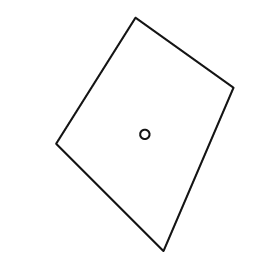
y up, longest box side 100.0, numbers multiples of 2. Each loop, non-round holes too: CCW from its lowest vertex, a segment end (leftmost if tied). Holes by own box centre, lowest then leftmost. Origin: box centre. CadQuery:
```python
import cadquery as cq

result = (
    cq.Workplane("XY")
    .moveTo(8.0, -50.0)
    .lineTo(38.0, 20.0)
    .lineTo(-4.0, 50.0)
    .lineTo(-38.0, -4.0)
    .close()
    .moveTo(0.0, 0.0)
    .circle(2.0)
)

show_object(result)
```